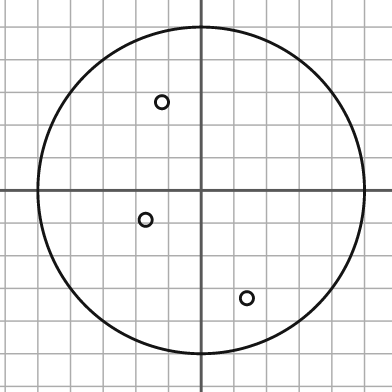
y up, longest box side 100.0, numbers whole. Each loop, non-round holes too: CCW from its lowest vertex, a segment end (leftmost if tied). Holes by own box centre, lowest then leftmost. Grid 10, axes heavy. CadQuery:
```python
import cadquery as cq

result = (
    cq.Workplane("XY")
    .moveTo(0.0, 0.0)
    .circle(50.0)
    .moveTo(14.0, -33.0)
    .circle(2.0)
    .moveTo(-17.0, -9.0)
    .circle(2.0)
    .moveTo(-12.0, 27.0)
    .circle(2.0)
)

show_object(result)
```